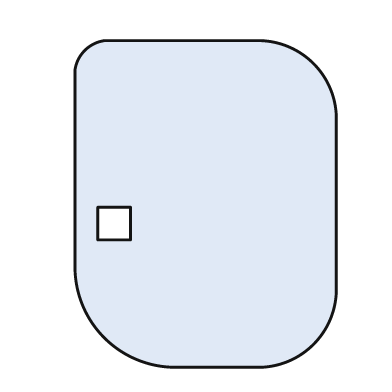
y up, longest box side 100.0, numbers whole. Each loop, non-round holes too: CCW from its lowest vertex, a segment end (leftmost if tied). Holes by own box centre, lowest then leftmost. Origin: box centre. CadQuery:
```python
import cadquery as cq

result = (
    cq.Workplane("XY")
    .moveTo(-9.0, -50.0)
    .lineTo(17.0, -50.0)
    .threePointArc((33.0, -43.0), (40.0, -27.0))
    .lineTo(40.0, 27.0)
    .threePointArc((33.0, 43.0), (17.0, 50.0))
    .lineTo(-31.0, 50.0)
    .threePointArc((-37.0, 47.0), (-40.0, 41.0))
    .lineTo(-40.0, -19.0)
    .threePointArc((-31.0, -41.0), (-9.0, -50.0))
    .close()
    .moveTo(-33.0, -11.0)
    .lineTo(-23.0, -11.0)
    .lineTo(-23.0, -1.0)
    .lineTo(-33.0, -1.0)
    .close()
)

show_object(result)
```